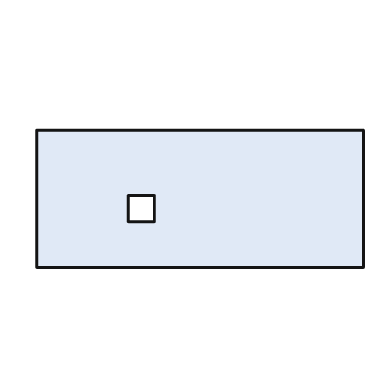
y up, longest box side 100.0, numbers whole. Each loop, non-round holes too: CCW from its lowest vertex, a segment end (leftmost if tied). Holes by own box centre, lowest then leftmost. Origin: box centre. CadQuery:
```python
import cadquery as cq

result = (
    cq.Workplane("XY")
    .moveTo(-50.0, -21.0)
    .lineTo(50.0, -21.0)
    .lineTo(50.0, 21.0)
    .lineTo(-50.0, 21.0)
    .close()
    .moveTo(-22.0, -7.0)
    .lineTo(-14.0, -7.0)
    .lineTo(-14.0, 1.0)
    .lineTo(-22.0, 1.0)
    .close()
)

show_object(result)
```